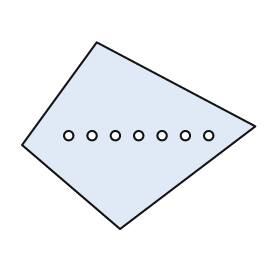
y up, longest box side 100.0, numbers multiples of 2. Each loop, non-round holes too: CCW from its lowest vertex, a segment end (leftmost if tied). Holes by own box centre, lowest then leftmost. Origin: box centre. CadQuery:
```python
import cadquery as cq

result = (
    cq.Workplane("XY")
    .moveTo(-8.0, -40.0)
    .lineTo(50.0, 4.0)
    .lineTo(-18.0, 40.0)
    .lineTo(-50.0, -4.0)
    .close()
    .moveTo(-30.0, 0.0)
    .circle(2.0)
    .moveTo(-20.0, 0.0)
    .circle(2.0)
    .moveTo(-10.0, 0.0)
    .circle(2.0)
    .moveTo(0.0, 0.0)
    .circle(2.0)
    .moveTo(10.0, 0.0)
    .circle(2.0)
    .moveTo(20.0, 0.0)
    .circle(2.0)
    .moveTo(30.0, 0.0)
    .circle(2.0)
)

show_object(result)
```